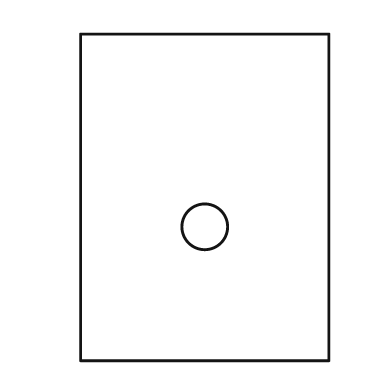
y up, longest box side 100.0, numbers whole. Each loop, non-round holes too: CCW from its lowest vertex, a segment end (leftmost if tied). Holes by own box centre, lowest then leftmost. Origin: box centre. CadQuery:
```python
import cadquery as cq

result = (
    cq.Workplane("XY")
    .moveTo(-38.0, -50.0)
    .lineTo(38.0, -50.0)
    .lineTo(38.0, 50.0)
    .lineTo(-38.0, 50.0)
    .close()
    .moveTo(0.0, -9.0)
    .circle(7.0)
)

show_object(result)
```